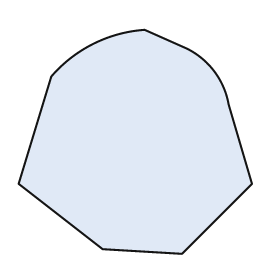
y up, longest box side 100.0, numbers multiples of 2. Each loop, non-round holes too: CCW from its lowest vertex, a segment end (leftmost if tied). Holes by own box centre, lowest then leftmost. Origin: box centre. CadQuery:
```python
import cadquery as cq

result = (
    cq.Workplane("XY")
    .moveTo(20.0, -48.0)
    .lineTo(50.0, -18.0)
    .lineTo(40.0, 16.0)
    .threePointArc((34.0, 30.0), (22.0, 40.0))
    .lineTo(4.0, 48.0)
    .threePointArc((-18.0, 42.0), (-36.0, 28.0))
    .lineTo(-50.0, -18.0)
    .lineTo(-14.0, -46.0)
    .close()
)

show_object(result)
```